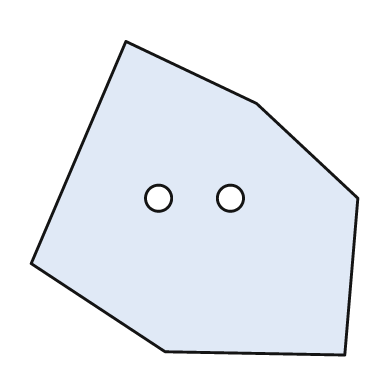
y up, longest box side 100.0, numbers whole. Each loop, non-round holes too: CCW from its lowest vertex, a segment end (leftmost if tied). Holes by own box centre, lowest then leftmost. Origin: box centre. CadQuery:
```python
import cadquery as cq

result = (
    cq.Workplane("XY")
    .moveTo(46.0, -48.0)
    .lineTo(50.0, 0.0)
    .lineTo(19.0, 29.0)
    .lineTo(-21.0, 48.0)
    .lineTo(-50.0, -20.0)
    .lineTo(-9.0, -47.0)
    .close()
    .moveTo(-11.0, 0.0)
    .circle(4.0)
    .moveTo(11.0, 0.0)
    .circle(4.0)
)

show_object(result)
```